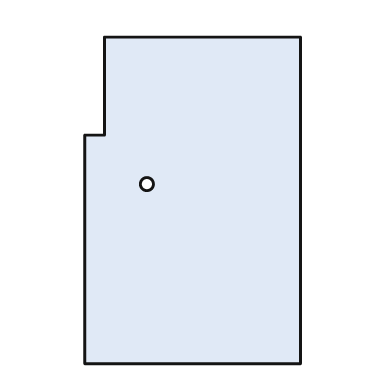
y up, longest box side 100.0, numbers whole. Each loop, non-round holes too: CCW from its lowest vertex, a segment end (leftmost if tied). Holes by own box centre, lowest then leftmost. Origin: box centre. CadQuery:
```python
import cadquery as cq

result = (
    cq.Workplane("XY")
    .moveTo(-33.0, -50.0)
    .lineTo(33.0, -50.0)
    .lineTo(33.0, 50.0)
    .lineTo(-27.0, 50.0)
    .lineTo(-27.0, 20.0)
    .lineTo(-33.0, 20.0)
    .close()
    .moveTo(-14.0, 5.0)
    .circle(2.0)
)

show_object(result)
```